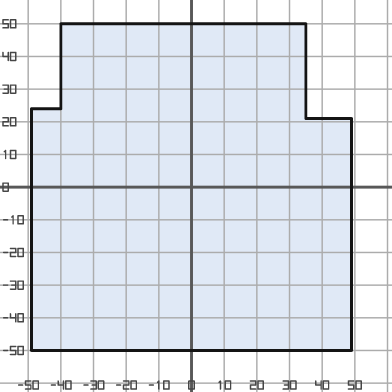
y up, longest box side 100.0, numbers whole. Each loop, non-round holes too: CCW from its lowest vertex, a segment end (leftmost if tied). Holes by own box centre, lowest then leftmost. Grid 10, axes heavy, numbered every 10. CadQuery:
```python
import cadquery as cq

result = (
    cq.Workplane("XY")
    .moveTo(-49.0, -50.0)
    .lineTo(49.0, -50.0)
    .lineTo(49.0, 21.0)
    .lineTo(35.0, 21.0)
    .lineTo(35.0, 50.0)
    .lineTo(-40.0, 50.0)
    .lineTo(-40.0, 24.0)
    .lineTo(-49.0, 24.0)
    .close()
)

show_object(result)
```